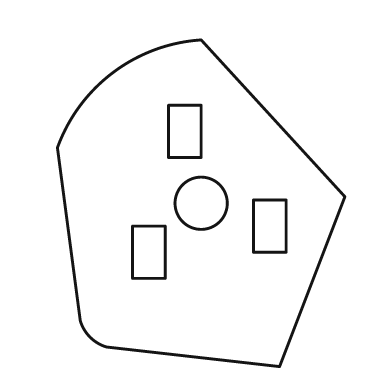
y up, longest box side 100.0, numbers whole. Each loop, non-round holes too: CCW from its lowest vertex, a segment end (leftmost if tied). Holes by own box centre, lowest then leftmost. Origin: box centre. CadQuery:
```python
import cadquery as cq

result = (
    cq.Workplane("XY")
    .moveTo(24.0, -50.0)
    .lineTo(44.0, 2.0)
    .lineTo(0.0, 50.0)
    .threePointArc((-27.0, 40.0), (-44.0, 17.0))
    .lineTo(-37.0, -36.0)
    .threePointArc((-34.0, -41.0), (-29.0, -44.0))
    .close()
    .moveTo(-21.0, -23.0)
    .lineTo(-11.0, -23.0)
    .lineTo(-11.0, -7.0)
    .lineTo(-21.0, -7.0)
    .close()
    .moveTo(16.0, -15.0)
    .lineTo(26.0, -15.0)
    .lineTo(26.0, 1.0)
    .lineTo(16.0, 1.0)
    .close()
    .moveTo(0.0, 0.0)
    .circle(8.0)
    .moveTo(-10.0, 14.0)
    .lineTo(0.0, 14.0)
    .lineTo(0.0, 30.0)
    .lineTo(-10.0, 30.0)
    .close()
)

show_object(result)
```